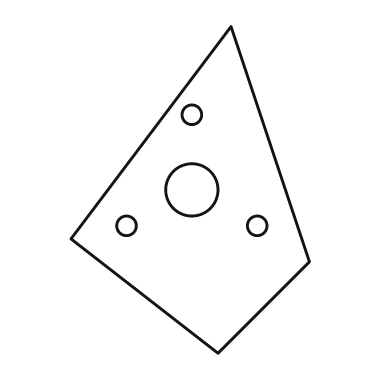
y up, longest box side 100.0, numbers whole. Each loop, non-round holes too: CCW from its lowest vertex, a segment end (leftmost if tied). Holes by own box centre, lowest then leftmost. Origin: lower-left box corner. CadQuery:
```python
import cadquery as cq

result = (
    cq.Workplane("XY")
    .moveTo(45.0, 0.0)
    .lineTo(73.0, 28.0)
    .lineTo(49.0, 100.0)
    .lineTo(0.0, 35.0)
    .close()
    .moveTo(17.0, 39.0)
    .circle(3.0)
    .moveTo(57.0, 39.0)
    .circle(3.0)
    .moveTo(37.0, 50.0)
    .circle(8.0)
    .moveTo(37.0, 73.0)
    .circle(3.0)
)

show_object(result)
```